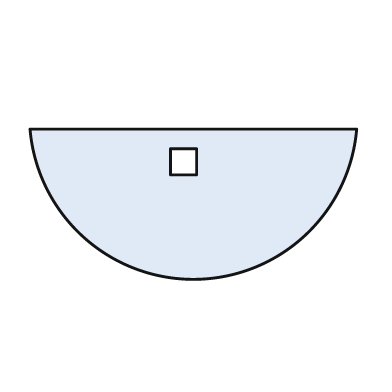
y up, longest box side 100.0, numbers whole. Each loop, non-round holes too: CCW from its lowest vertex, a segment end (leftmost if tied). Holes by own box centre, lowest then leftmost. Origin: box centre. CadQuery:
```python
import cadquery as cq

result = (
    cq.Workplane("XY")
    .moveTo(-50.0, 23.0)
    .threePointArc((0.0, -23.0), (50.0, 23.0))
    .close()
    .moveTo(-7.0, 9.0)
    .lineTo(1.0, 9.0)
    .lineTo(1.0, 17.0)
    .lineTo(-7.0, 17.0)
    .close()
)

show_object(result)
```